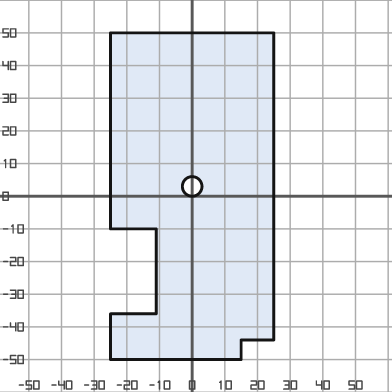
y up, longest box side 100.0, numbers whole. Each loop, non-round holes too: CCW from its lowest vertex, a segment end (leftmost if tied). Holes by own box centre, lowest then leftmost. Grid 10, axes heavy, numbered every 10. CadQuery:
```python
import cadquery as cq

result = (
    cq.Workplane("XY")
    .moveTo(-25.0, -50.0)
    .lineTo(15.0, -50.0)
    .lineTo(15.0, -44.0)
    .lineTo(25.0, -44.0)
    .lineTo(25.0, 50.0)
    .lineTo(-25.0, 50.0)
    .lineTo(-25.0, -10.0)
    .lineTo(-11.0, -10.0)
    .lineTo(-11.0, -36.0)
    .lineTo(-25.0, -36.0)
    .close()
    .moveTo(0.0, 3.0)
    .circle(3.0)
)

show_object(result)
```